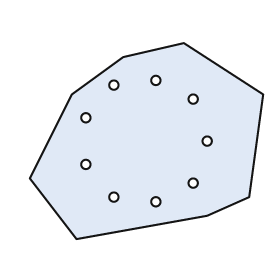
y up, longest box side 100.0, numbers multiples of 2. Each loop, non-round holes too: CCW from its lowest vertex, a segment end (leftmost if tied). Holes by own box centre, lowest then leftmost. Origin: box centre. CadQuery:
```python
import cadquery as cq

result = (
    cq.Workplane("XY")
    .moveTo(-30.0, -42.0)
    .lineTo(26.0, -32.0)
    .lineTo(44.0, -24.0)
    .lineTo(50.0, 20.0)
    .lineTo(16.0, 42.0)
    .lineTo(-10.0, 36.0)
    .lineTo(-32.0, 20.0)
    .lineTo(-50.0, -16.0)
    .close()
    .moveTo(4.0, -26.0)
    .circle(2.0)
    .moveTo(-14.0, -24.0)
    .circle(2.0)
    .moveTo(20.0, -18.0)
    .circle(2.0)
    .moveTo(-26.0, -10.0)
    .circle(2.0)
    .moveTo(26.0, 0.0)
    .circle(2.0)
    .moveTo(-26.0, 10.0)
    .circle(2.0)
    .moveTo(20.0, 18.0)
    .circle(2.0)
    .moveTo(-14.0, 24.0)
    .circle(2.0)
    .moveTo(4.0, 26.0)
    .circle(2.0)
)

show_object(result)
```